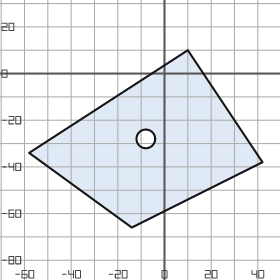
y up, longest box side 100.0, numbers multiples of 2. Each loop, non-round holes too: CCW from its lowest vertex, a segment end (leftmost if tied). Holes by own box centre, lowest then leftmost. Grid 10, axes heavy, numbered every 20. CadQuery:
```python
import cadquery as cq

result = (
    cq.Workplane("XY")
    .moveTo(-14.0, -66.0)
    .lineTo(42.0, -38.0)
    .lineTo(10.0, 10.0)
    .lineTo(-58.0, -34.0)
    .close()
    .moveTo(-8.0, -28.0)
    .circle(4.0)
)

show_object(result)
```